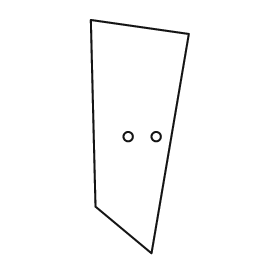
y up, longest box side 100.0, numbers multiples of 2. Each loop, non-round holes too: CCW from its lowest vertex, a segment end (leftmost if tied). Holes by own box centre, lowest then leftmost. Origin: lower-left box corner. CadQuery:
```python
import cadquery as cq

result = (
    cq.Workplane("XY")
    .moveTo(26.0, 0.0)
    .lineTo(42.0, 94.0)
    .lineTo(0.0, 100.0)
    .lineTo(2.0, 20.0)
    .close()
    .moveTo(16.0, 50.0)
    .circle(2.0)
    .moveTo(28.0, 50.0)
    .circle(2.0)
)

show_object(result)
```